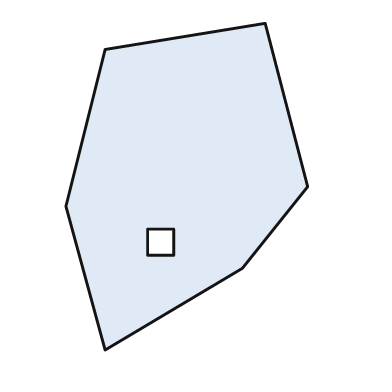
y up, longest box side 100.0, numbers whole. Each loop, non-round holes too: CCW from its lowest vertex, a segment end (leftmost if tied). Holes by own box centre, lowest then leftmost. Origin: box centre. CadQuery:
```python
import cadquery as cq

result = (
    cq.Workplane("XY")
    .moveTo(-25.0, -50.0)
    .lineTo(17.0, -25.0)
    .lineTo(37.0, 0.0)
    .lineTo(24.0, 50.0)
    .lineTo(-25.0, 42.0)
    .lineTo(-37.0, -6.0)
    .close()
    .moveTo(-12.0, -21.0)
    .lineTo(-4.0, -21.0)
    .lineTo(-4.0, -13.0)
    .lineTo(-12.0, -13.0)
    .close()
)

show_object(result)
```